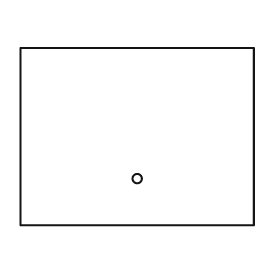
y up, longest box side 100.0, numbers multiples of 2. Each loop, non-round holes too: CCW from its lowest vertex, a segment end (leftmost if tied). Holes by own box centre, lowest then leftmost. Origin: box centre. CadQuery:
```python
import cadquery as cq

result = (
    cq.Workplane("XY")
    .moveTo(-50.0, -38.0)
    .lineTo(50.0, -38.0)
    .lineTo(50.0, 38.0)
    .lineTo(-50.0, 38.0)
    .close()
    .moveTo(0.0, -18.0)
    .circle(2.0)
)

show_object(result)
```